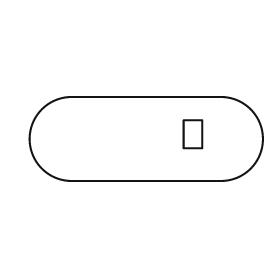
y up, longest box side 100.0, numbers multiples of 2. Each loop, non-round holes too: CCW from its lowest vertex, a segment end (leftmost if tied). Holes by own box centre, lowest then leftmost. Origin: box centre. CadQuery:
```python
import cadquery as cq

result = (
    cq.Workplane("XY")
    .moveTo(-32.0, -18.0)
    .lineTo(32.0, -18.0)
    .threePointArc((50.0, 0.0), (32.0, 18.0))
    .lineTo(-32.0, 18.0)
    .threePointArc((-50.0, 0.0), (-32.0, -18.0))
    .close()
    .moveTo(16.0, -4.0)
    .lineTo(24.0, -4.0)
    .lineTo(24.0, 8.0)
    .lineTo(16.0, 8.0)
    .close()
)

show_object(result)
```